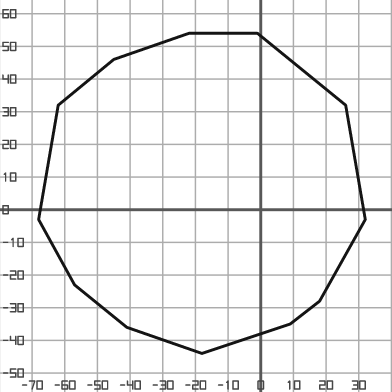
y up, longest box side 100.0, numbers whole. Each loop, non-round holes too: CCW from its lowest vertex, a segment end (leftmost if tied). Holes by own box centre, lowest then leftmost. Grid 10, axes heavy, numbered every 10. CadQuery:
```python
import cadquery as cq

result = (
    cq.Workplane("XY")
    .moveTo(-18.0, -44.0)
    .lineTo(9.0, -35.0)
    .lineTo(18.0, -28.0)
    .lineTo(32.0, -3.0)
    .lineTo(26.0, 32.0)
    .lineTo(-1.0, 54.0)
    .lineTo(-22.0, 54.0)
    .lineTo(-45.0, 46.0)
    .lineTo(-62.0, 32.0)
    .lineTo(-68.0, -3.0)
    .lineTo(-57.0, -23.0)
    .lineTo(-41.0, -36.0)
    .close()
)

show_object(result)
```